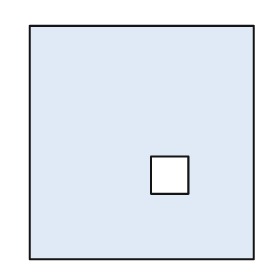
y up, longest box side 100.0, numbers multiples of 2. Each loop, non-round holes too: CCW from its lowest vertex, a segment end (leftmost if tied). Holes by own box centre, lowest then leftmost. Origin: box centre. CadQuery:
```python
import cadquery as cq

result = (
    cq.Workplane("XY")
    .moveTo(-48.0, -50.0)
    .lineTo(48.0, -50.0)
    .lineTo(48.0, 50.0)
    .lineTo(-48.0, 50.0)
    .close()
    .moveTo(4.0, -22.0)
    .lineTo(20.0, -22.0)
    .lineTo(20.0, -6.0)
    .lineTo(4.0, -6.0)
    .close()
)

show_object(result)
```